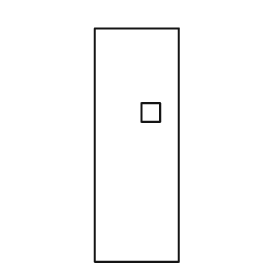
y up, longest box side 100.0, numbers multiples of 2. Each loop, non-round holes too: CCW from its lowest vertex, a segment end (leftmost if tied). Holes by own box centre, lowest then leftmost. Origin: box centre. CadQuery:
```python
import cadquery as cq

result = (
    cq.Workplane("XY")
    .moveTo(-18.0, -50.0)
    .lineTo(18.0, -50.0)
    .lineTo(18.0, 50.0)
    .lineTo(-18.0, 50.0)
    .close()
    .moveTo(2.0, 10.0)
    .lineTo(10.0, 10.0)
    .lineTo(10.0, 18.0)
    .lineTo(2.0, 18.0)
    .close()
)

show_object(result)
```